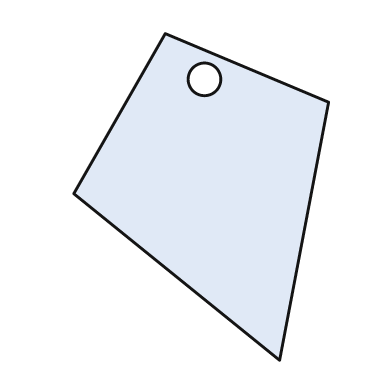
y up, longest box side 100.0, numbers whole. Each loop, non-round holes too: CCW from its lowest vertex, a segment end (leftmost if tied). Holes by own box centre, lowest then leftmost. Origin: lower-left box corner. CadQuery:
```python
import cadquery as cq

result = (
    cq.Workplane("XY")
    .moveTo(63.0, 0.0)
    .lineTo(78.0, 79.0)
    .lineTo(28.0, 100.0)
    .lineTo(0.0, 51.0)
    .close()
    .moveTo(40.0, 86.0)
    .circle(5.0)
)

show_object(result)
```